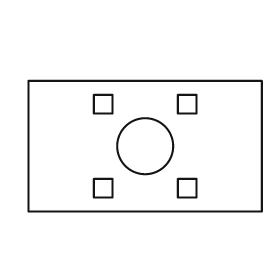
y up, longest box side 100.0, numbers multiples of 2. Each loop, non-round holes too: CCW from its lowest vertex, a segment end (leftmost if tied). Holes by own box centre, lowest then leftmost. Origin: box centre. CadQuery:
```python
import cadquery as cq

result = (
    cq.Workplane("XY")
    .moveTo(-50.0, -28.0)
    .lineTo(50.0, -28.0)
    .lineTo(50.0, 28.0)
    .lineTo(-50.0, 28.0)
    .close()
    .moveTo(-22.0, -22.0)
    .lineTo(-14.0, -22.0)
    .lineTo(-14.0, -14.0)
    .lineTo(-22.0, -14.0)
    .close()
    .moveTo(14.0, -22.0)
    .lineTo(22.0, -22.0)
    .lineTo(22.0, -14.0)
    .lineTo(14.0, -14.0)
    .close()
    .moveTo(0.0, 0.0)
    .circle(12.0)
    .moveTo(-22.0, 14.0)
    .lineTo(-14.0, 14.0)
    .lineTo(-14.0, 22.0)
    .lineTo(-22.0, 22.0)
    .close()
    .moveTo(14.0, 14.0)
    .lineTo(22.0, 14.0)
    .lineTo(22.0, 22.0)
    .lineTo(14.0, 22.0)
    .close()
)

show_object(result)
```